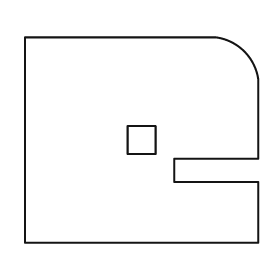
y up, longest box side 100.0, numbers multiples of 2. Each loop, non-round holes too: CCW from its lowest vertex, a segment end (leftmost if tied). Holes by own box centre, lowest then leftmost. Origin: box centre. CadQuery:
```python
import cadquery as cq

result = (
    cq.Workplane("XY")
    .moveTo(-50.0, -44.0)
    .lineTo(50.0, -44.0)
    .lineTo(50.0, -18.0)
    .lineTo(14.0, -18.0)
    .lineTo(14.0, -8.0)
    .lineTo(50.0, -8.0)
    .lineTo(50.0, 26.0)
    .threePointArc((44.0, 38.0), (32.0, 44.0))
    .lineTo(-50.0, 44.0)
    .close()
    .moveTo(-6.0, -6.0)
    .lineTo(6.0, -6.0)
    .lineTo(6.0, 6.0)
    .lineTo(-6.0, 6.0)
    .close()
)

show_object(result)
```